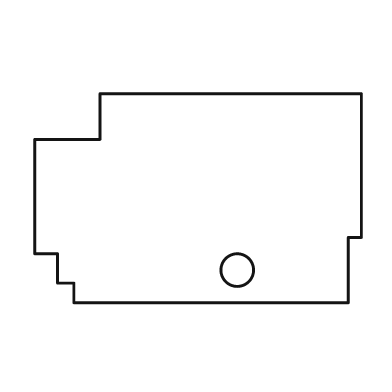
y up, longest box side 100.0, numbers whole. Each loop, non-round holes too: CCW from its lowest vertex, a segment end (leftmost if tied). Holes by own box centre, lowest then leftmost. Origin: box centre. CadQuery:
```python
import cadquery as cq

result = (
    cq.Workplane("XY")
    .moveTo(-38.0, -32.0)
    .lineTo(46.0, -32.0)
    .lineTo(46.0, -12.0)
    .lineTo(50.0, -12.0)
    .lineTo(50.0, 32.0)
    .lineTo(-30.0, 32.0)
    .lineTo(-30.0, 18.0)
    .lineTo(-50.0, 18.0)
    .lineTo(-50.0, -17.0)
    .lineTo(-43.0, -17.0)
    .lineTo(-43.0, -26.0)
    .lineTo(-38.0, -26.0)
    .close()
    .moveTo(12.0, -22.0)
    .circle(5.0)
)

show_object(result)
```